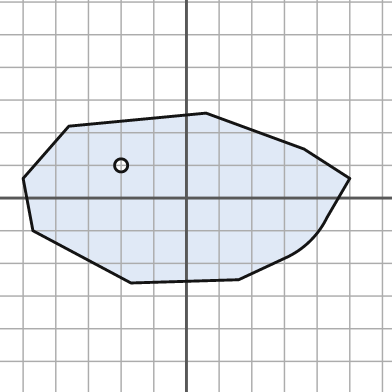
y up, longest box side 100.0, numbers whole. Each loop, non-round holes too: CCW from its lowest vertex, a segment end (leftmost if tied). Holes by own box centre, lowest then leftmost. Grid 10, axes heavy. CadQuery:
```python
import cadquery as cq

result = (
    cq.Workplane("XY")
    .moveTo(-17.0, -26.0)
    .lineTo(16.0, -25.0)
    .lineTo(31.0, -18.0)
    .threePointArc((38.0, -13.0), (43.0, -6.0))
    .lineTo(50.0, 6.0)
    .lineTo(36.0, 15.0)
    .lineTo(6.0, 26.0)
    .lineTo(-36.0, 22.0)
    .lineTo(-50.0, 6.0)
    .lineTo(-47.0, -10.0)
    .close()
    .moveTo(-20.0, 10.0)
    .circle(2.0)
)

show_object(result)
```